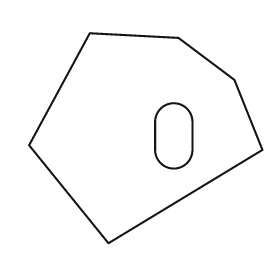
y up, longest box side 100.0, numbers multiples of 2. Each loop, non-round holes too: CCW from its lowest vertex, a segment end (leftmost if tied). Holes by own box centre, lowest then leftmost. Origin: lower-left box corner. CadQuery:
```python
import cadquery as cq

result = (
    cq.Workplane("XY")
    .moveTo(34.0, 0.0)
    .lineTo(100.0, 40.0)
    .lineTo(88.0, 70.0)
    .lineTo(64.0, 88.0)
    .lineTo(26.0, 90.0)
    .lineTo(0.0, 42.0)
    .close()
    .moveTo(54.0, 40.0)
    .threePointArc((62.0, 32.0), (70.0, 40.0))
    .lineTo(70.0, 52.0)
    .threePointArc((62.0, 60.0), (54.0, 52.0))
    .close()
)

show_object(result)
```